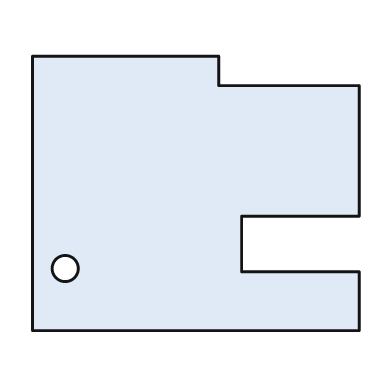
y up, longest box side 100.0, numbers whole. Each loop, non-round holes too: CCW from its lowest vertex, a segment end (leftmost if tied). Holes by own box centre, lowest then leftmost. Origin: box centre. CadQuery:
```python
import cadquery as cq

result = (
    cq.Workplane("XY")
    .moveTo(-50.0, -42.0)
    .lineTo(50.0, -42.0)
    .lineTo(50.0, -24.0)
    .lineTo(14.0, -24.0)
    .lineTo(14.0, -7.0)
    .lineTo(50.0, -7.0)
    .lineTo(50.0, 33.0)
    .lineTo(7.0, 33.0)
    .lineTo(7.0, 42.0)
    .lineTo(-50.0, 42.0)
    .close()
    .moveTo(-40.0, -23.0)
    .circle(4.0)
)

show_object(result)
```